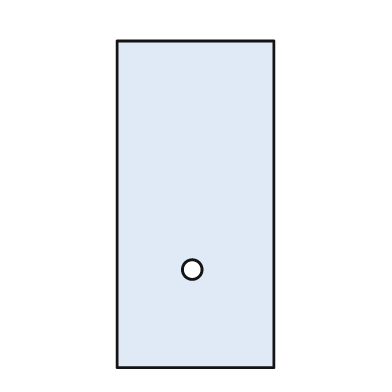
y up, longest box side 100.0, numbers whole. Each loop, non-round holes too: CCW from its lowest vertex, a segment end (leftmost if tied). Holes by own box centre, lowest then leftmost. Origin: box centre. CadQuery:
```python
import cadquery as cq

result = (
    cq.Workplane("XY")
    .moveTo(-24.0, -50.0)
    .lineTo(24.0, -50.0)
    .lineTo(24.0, 50.0)
    .lineTo(-24.0, 50.0)
    .close()
    .moveTo(-1.0, -20.0)
    .circle(3.0)
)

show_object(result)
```